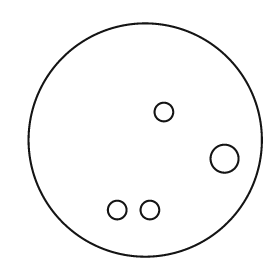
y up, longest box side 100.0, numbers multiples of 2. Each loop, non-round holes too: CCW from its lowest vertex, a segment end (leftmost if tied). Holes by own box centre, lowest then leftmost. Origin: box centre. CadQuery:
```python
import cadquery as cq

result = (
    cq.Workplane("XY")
    .moveTo(0.0, 0.0)
    .circle(50.0)
    .moveTo(-12.0, -30.0)
    .circle(4.0)
    .moveTo(2.0, -30.0)
    .circle(4.0)
    .moveTo(34.0, -8.0)
    .circle(6.0)
    .moveTo(8.0, 12.0)
    .circle(4.0)
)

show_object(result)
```